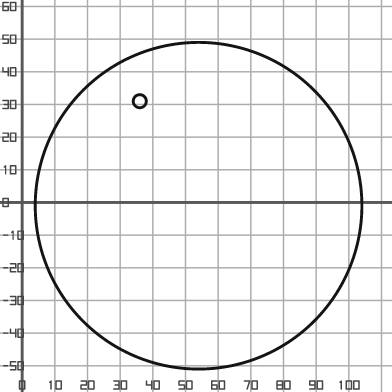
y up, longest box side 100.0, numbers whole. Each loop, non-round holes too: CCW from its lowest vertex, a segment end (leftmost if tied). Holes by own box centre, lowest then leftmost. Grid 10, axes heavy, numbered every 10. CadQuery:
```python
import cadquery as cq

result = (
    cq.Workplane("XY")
    .moveTo(54.0, -1.0)
    .circle(50.0)
    .moveTo(36.0, 31.0)
    .circle(2.0)
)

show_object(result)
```